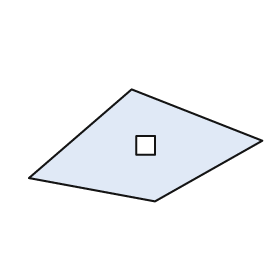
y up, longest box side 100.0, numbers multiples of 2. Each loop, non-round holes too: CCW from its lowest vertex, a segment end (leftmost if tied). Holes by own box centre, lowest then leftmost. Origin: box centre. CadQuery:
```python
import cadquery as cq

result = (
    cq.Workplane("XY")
    .moveTo(4.0, -24.0)
    .lineTo(50.0, 2.0)
    .lineTo(-6.0, 24.0)
    .lineTo(-50.0, -14.0)
    .close()
    .moveTo(-4.0, -4.0)
    .lineTo(4.0, -4.0)
    .lineTo(4.0, 4.0)
    .lineTo(-4.0, 4.0)
    .close()
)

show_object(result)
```